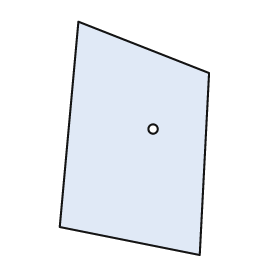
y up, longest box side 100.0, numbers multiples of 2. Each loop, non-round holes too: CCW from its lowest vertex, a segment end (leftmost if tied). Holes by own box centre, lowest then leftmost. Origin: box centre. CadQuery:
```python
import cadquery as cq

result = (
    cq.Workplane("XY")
    .moveTo(28.0, -50.0)
    .lineTo(32.0, 28.0)
    .lineTo(-24.0, 50.0)
    .lineTo(-32.0, -38.0)
    .close()
    .moveTo(8.0, 4.0)
    .circle(2.0)
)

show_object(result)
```